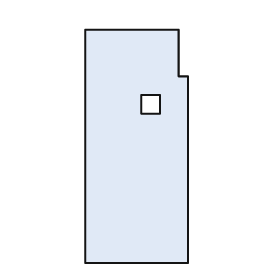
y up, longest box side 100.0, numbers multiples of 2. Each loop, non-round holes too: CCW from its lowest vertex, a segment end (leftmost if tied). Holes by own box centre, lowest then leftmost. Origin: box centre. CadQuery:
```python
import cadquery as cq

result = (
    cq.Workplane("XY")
    .moveTo(-22.0, -50.0)
    .lineTo(22.0, -50.0)
    .lineTo(22.0, 30.0)
    .lineTo(18.0, 30.0)
    .lineTo(18.0, 50.0)
    .lineTo(-22.0, 50.0)
    .close()
    .moveTo(2.0, 14.0)
    .lineTo(10.0, 14.0)
    .lineTo(10.0, 22.0)
    .lineTo(2.0, 22.0)
    .close()
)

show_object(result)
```